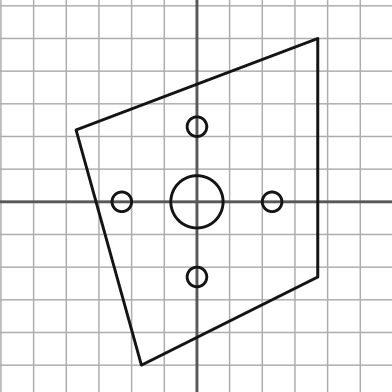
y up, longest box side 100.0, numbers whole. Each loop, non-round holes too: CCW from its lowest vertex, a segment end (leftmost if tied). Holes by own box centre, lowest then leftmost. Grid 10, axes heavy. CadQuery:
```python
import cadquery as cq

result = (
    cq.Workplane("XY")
    .moveTo(-17.0, -50.0)
    .lineTo(37.0, -23.0)
    .lineTo(37.0, 50.0)
    .lineTo(-37.0, 22.0)
    .close()
    .moveTo(0.0, -23.0)
    .circle(3.0)
    .moveTo(-23.0, 0.0)
    .circle(3.0)
    .moveTo(0.0, 0.0)
    .circle(8.0)
    .moveTo(23.0, 0.0)
    .circle(3.0)
    .moveTo(0.0, 23.0)
    .circle(3.0)
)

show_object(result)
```